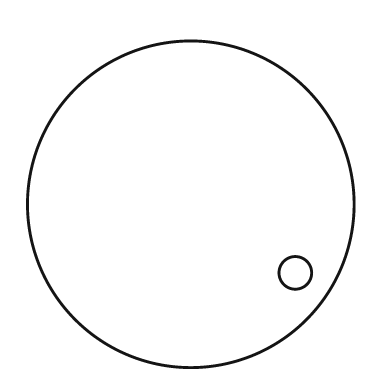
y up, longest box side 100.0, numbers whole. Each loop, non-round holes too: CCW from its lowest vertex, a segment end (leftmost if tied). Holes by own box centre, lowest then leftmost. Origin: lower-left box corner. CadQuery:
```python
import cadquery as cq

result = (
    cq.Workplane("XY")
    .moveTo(50.0, 50.0)
    .circle(50.0)
    .moveTo(82.0, 29.0)
    .circle(5.0)
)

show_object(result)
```